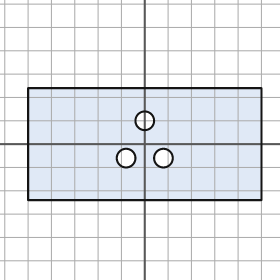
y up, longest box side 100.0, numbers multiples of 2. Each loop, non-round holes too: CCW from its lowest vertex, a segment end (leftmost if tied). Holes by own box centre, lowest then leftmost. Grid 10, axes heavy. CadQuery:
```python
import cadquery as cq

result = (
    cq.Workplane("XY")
    .moveTo(-50.0, -24.0)
    .lineTo(50.0, -24.0)
    .lineTo(50.0, 24.0)
    .lineTo(-50.0, 24.0)
    .close()
    .moveTo(-8.0, -6.0)
    .circle(4.0)
    .moveTo(8.0, -6.0)
    .circle(4.0)
    .moveTo(0.0, 10.0)
    .circle(4.0)
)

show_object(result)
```